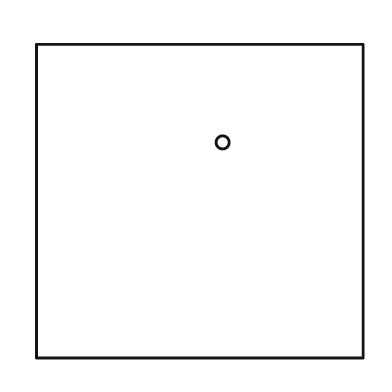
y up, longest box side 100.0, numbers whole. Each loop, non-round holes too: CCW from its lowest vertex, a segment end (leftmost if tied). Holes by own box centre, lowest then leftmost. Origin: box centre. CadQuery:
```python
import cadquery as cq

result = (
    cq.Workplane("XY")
    .moveTo(-50.0, -48.0)
    .lineTo(50.0, -48.0)
    .lineTo(50.0, 48.0)
    .lineTo(-50.0, 48.0)
    .close()
    .moveTo(7.0, 18.0)
    .circle(2.0)
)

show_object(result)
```